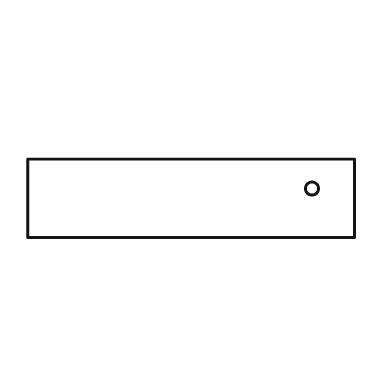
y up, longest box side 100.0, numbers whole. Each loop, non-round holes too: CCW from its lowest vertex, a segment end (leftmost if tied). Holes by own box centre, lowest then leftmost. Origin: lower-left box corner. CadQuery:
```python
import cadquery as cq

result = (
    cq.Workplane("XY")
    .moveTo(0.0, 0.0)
    .lineTo(100.0, 0.0)
    .lineTo(100.0, 24.0)
    .lineTo(0.0, 24.0)
    .close()
    .moveTo(87.0, 15.0)
    .circle(2.0)
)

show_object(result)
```